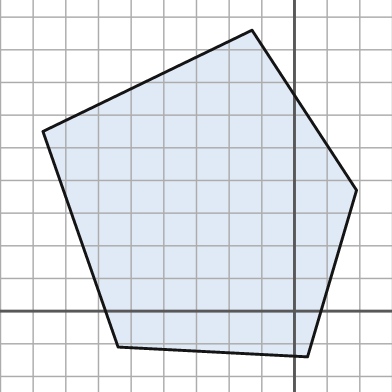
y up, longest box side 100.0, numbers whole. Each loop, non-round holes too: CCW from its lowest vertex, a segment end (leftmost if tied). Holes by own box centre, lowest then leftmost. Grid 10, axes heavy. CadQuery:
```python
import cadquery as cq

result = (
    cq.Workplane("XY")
    .moveTo(4.0, -14.0)
    .lineTo(19.0, 37.0)
    .lineTo(-13.0, 86.0)
    .lineTo(-77.0, 55.0)
    .lineTo(-54.0, -11.0)
    .close()
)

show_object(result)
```